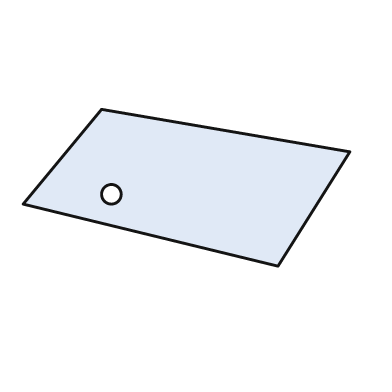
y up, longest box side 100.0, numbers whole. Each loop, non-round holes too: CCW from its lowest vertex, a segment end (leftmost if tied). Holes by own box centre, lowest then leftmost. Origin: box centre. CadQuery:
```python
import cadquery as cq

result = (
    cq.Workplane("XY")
    .moveTo(28.0, -24.0)
    .lineTo(50.0, 11.0)
    .lineTo(-26.0, 24.0)
    .lineTo(-50.0, -5.0)
    .close()
    .moveTo(-23.0, -2.0)
    .circle(3.0)
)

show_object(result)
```